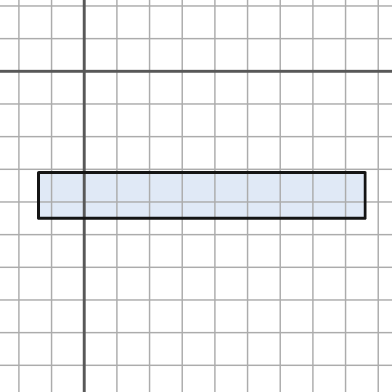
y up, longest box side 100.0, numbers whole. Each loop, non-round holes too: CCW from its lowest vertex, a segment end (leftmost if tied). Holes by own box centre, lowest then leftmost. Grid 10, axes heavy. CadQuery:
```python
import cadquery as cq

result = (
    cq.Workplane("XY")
    .moveTo(-14.0, -45.0)
    .lineTo(86.0, -45.0)
    .lineTo(86.0, -31.0)
    .lineTo(-14.0, -31.0)
    .close()
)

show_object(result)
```